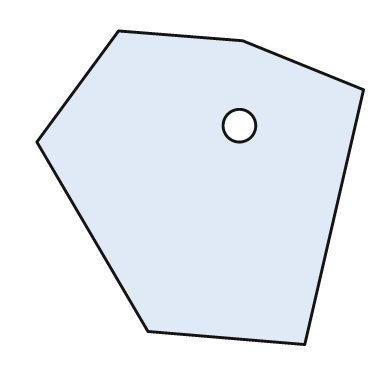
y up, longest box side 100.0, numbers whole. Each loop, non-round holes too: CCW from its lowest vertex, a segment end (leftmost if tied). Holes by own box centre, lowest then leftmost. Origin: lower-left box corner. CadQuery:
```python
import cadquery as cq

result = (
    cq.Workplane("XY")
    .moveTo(82.0, 0.0)
    .lineTo(100.0, 78.0)
    .lineTo(63.0, 93.0)
    .lineTo(25.0, 96.0)
    .lineTo(0.0, 62.0)
    .lineTo(34.0, 4.0)
    .close()
    .moveTo(62.0, 67.0)
    .circle(5.0)
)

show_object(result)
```